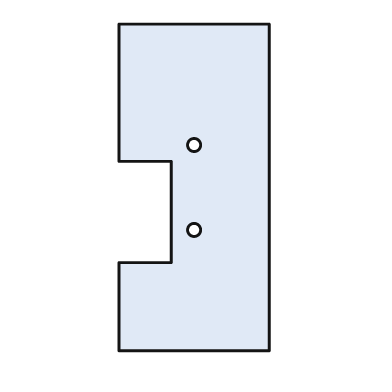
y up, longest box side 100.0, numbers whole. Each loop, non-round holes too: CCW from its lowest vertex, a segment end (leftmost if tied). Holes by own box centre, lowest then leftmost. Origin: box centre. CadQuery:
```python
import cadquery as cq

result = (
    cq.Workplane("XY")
    .moveTo(-23.0, -50.0)
    .lineTo(23.0, -50.0)
    .lineTo(23.0, 50.0)
    .lineTo(-23.0, 50.0)
    .lineTo(-23.0, 8.0)
    .lineTo(-7.0, 8.0)
    .lineTo(-7.0, -23.0)
    .lineTo(-23.0, -23.0)
    .close()
    .moveTo(0.0, -13.0)
    .circle(2.0)
    .moveTo(0.0, 13.0)
    .circle(2.0)
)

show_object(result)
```